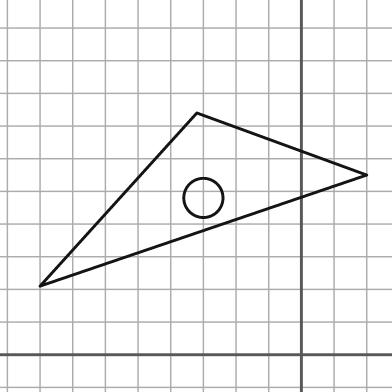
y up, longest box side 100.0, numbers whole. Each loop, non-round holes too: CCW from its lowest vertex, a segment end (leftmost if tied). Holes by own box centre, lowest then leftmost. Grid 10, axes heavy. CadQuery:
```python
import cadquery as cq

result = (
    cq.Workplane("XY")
    .moveTo(-80.0, 21.0)
    .lineTo(20.0, 55.0)
    .lineTo(-32.0, 74.0)
    .close()
    .moveTo(-30.0, 48.0)
    .circle(6.0)
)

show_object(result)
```